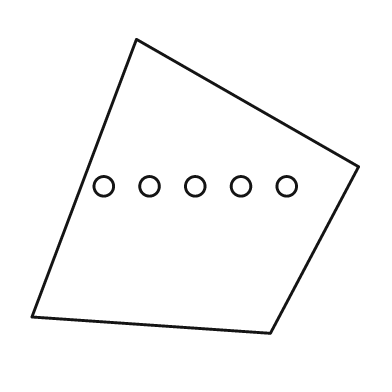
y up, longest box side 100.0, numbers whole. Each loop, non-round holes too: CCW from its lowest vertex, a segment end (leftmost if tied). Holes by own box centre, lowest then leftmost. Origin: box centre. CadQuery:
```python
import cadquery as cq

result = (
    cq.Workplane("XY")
    .moveTo(23.0, -45.0)
    .lineTo(50.0, 6.0)
    .lineTo(-18.0, 45.0)
    .lineTo(-50.0, -40.0)
    .close()
    .moveTo(-28.0, 0.0)
    .circle(3.0)
    .moveTo(-14.0, 0.0)
    .circle(3.0)
    .moveTo(0.0, 0.0)
    .circle(3.0)
    .moveTo(14.0, 0.0)
    .circle(3.0)
    .moveTo(28.0, 0.0)
    .circle(3.0)
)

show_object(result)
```